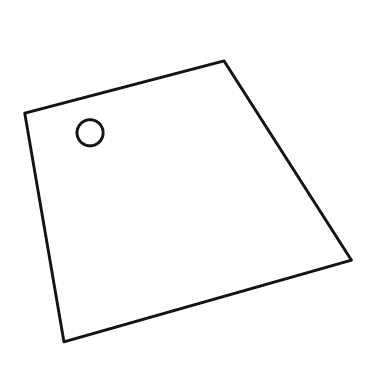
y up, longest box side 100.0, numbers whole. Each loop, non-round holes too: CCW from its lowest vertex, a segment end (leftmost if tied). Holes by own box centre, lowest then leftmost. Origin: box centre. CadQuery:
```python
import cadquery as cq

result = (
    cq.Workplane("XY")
    .moveTo(-38.0, -43.0)
    .lineTo(50.0, -18.0)
    .lineTo(11.0, 43.0)
    .lineTo(-50.0, 27.0)
    .close()
    .moveTo(-30.0, 21.0)
    .circle(4.0)
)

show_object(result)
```